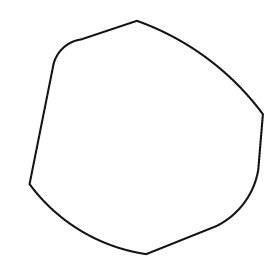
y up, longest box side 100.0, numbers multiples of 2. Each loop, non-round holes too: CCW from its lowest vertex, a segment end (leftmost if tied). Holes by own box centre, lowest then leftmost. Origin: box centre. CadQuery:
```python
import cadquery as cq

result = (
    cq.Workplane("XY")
    .moveTo(0.0, -50.0)
    .lineTo(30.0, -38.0)
    .threePointArc((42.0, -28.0), (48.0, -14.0))
    .lineTo(50.0, 10.0)
    .threePointArc((26.0, 34.0), (-4.0, 50.0))
    .lineTo(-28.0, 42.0)
    .threePointArc((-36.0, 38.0), (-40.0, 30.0))
    .lineTo(-50.0, -20.0)
    .threePointArc((-28.0, -40.0), (0.0, -50.0))
    .close()
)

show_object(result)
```